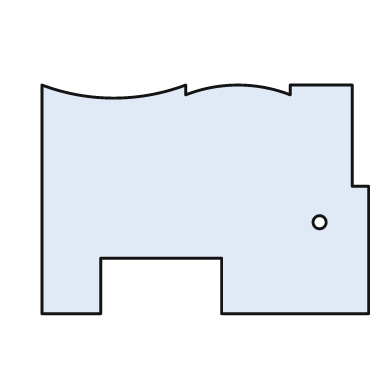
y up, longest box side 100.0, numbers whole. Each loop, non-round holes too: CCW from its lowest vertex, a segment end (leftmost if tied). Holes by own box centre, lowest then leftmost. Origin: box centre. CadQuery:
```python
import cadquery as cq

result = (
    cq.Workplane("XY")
    .moveTo(-50.0, -35.0)
    .lineTo(-32.0, -35.0)
    .lineTo(-32.0, -18.0)
    .lineTo(5.0, -18.0)
    .lineTo(5.0, -35.0)
    .lineTo(50.0, -35.0)
    .lineTo(50.0, 4.0)
    .lineTo(45.0, 4.0)
    .lineTo(45.0, 35.0)
    .lineTo(26.0, 35.0)
    .lineTo(26.0, 32.0)
    .threePointArc((10.0, 35.0), (-6.0, 32.0))
    .lineTo(-6.0, 35.0)
    .threePointArc((-28.0, 31.0), (-50.0, 35.0))
    .close()
    .moveTo(35.0, -7.0)
    .circle(2.0)
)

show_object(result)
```